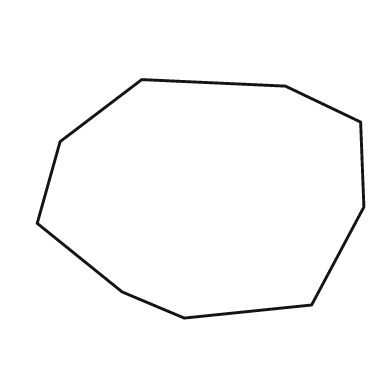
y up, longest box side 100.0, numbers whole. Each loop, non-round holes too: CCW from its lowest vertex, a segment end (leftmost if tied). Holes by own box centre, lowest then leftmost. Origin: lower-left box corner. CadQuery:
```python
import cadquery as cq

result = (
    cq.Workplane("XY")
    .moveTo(45.0, 0.0)
    .lineTo(84.0, 4.0)
    .lineTo(100.0, 34.0)
    .lineTo(99.0, 60.0)
    .lineTo(76.0, 71.0)
    .lineTo(32.0, 73.0)
    .lineTo(7.0, 54.0)
    .lineTo(0.0, 29.0)
    .lineTo(26.0, 8.0)
    .close()
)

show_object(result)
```